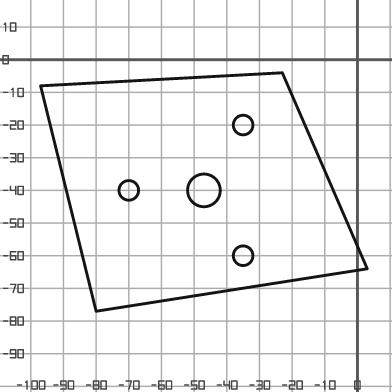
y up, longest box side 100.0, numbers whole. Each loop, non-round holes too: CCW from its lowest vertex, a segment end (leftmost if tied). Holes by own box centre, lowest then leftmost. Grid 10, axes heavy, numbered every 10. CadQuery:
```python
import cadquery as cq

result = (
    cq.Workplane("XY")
    .moveTo(-80.0, -77.0)
    .lineTo(3.0, -64.0)
    .lineTo(-23.0, -4.0)
    .lineTo(-97.0, -8.0)
    .close()
    .moveTo(-35.0, -60.0)
    .circle(3.0)
    .moveTo(-70.0, -40.0)
    .circle(3.0)
    .moveTo(-47.0, -40.0)
    .circle(5.0)
    .moveTo(-35.0, -20.0)
    .circle(3.0)
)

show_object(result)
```